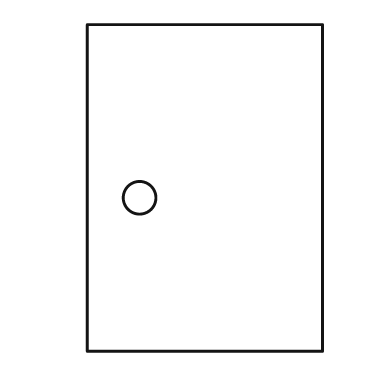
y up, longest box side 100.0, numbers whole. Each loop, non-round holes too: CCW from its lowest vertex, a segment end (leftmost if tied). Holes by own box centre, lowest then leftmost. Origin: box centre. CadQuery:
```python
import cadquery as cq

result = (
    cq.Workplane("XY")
    .moveTo(-36.0, -50.0)
    .lineTo(36.0, -50.0)
    .lineTo(36.0, 50.0)
    .lineTo(-36.0, 50.0)
    .close()
    .moveTo(-20.0, -3.0)
    .circle(5.0)
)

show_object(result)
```